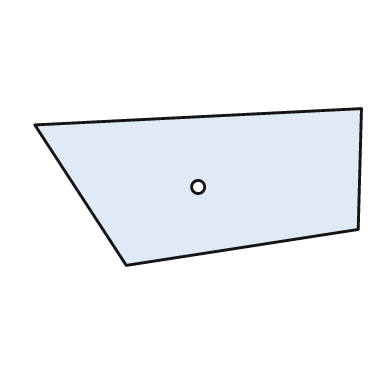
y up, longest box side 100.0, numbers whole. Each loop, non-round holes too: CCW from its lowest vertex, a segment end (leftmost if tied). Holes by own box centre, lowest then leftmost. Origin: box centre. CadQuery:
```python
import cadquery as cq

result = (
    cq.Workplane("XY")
    .moveTo(-22.0, -24.0)
    .lineTo(49.0, -13.0)
    .lineTo(50.0, 24.0)
    .lineTo(-50.0, 19.0)
    .close()
    .moveTo(0.0, 0.0)
    .circle(2.0)
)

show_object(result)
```